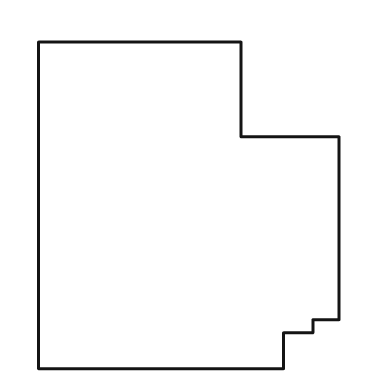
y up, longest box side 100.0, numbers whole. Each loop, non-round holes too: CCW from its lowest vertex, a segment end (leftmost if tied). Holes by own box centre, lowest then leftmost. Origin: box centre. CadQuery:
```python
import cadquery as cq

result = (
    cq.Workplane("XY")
    .moveTo(-46.0, -50.0)
    .lineTo(29.0, -50.0)
    .lineTo(29.0, -39.0)
    .lineTo(38.0, -39.0)
    .lineTo(38.0, -35.0)
    .lineTo(46.0, -35.0)
    .lineTo(46.0, 21.0)
    .lineTo(16.0, 21.0)
    .lineTo(16.0, 50.0)
    .lineTo(-46.0, 50.0)
    .close()
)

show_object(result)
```